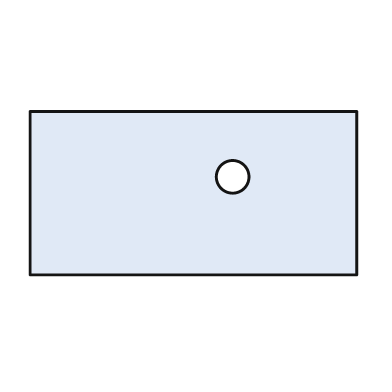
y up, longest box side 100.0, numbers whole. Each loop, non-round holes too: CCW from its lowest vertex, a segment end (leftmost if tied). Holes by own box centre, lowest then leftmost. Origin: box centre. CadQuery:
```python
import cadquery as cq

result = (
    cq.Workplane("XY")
    .moveTo(-50.0, -25.0)
    .lineTo(50.0, -25.0)
    .lineTo(50.0, 25.0)
    .lineTo(-50.0, 25.0)
    .close()
    .moveTo(12.0, 5.0)
    .circle(5.0)
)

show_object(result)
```